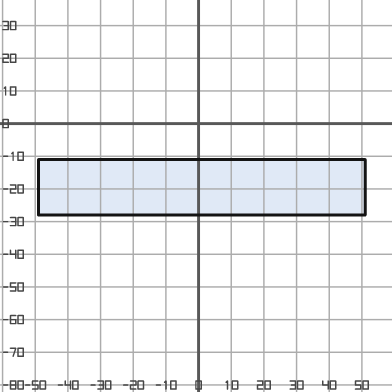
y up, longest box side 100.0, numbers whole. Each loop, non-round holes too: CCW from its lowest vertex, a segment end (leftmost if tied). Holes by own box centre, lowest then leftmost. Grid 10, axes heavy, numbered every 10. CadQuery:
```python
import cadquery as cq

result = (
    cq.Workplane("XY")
    .moveTo(-49.0, -28.0)
    .lineTo(51.0, -28.0)
    .lineTo(51.0, -11.0)
    .lineTo(-49.0, -11.0)
    .close()
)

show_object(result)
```